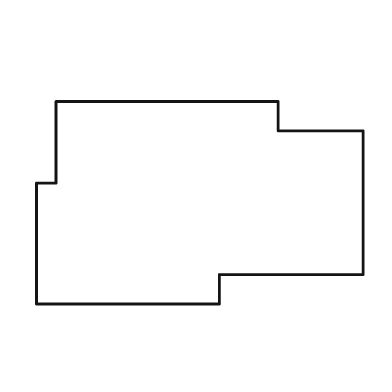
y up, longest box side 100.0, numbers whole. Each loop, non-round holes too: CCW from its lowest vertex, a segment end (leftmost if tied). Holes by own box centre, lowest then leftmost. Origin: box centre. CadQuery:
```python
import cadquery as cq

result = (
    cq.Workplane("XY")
    .moveTo(-50.0, -31.0)
    .lineTo(6.0, -31.0)
    .lineTo(6.0, -22.0)
    .lineTo(50.0, -22.0)
    .lineTo(50.0, 22.0)
    .lineTo(24.0, 22.0)
    .lineTo(24.0, 31.0)
    .lineTo(-44.0, 31.0)
    .lineTo(-44.0, 6.0)
    .lineTo(-50.0, 6.0)
    .close()
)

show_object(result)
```